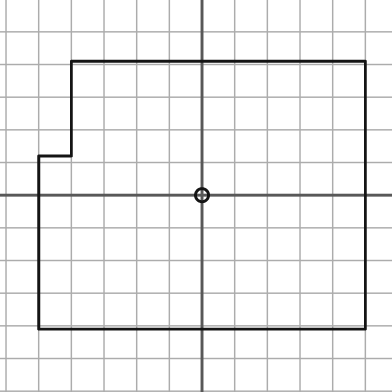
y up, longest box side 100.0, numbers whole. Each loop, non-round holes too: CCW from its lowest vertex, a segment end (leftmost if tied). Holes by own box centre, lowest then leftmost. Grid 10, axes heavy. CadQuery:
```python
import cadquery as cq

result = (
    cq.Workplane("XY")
    .moveTo(-50.0, -41.0)
    .lineTo(50.0, -41.0)
    .lineTo(50.0, 41.0)
    .lineTo(-40.0, 41.0)
    .lineTo(-40.0, 12.0)
    .lineTo(-50.0, 12.0)
    .close()
    .moveTo(0.0, 0.0)
    .circle(2.0)
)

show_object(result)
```